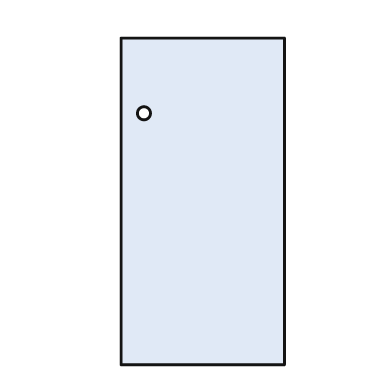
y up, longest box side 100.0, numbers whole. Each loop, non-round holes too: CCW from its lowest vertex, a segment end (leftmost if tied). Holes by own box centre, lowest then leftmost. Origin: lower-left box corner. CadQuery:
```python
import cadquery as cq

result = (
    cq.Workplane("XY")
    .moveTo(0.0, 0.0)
    .lineTo(50.0, 0.0)
    .lineTo(50.0, 100.0)
    .lineTo(0.0, 100.0)
    .close()
    .moveTo(7.0, 77.0)
    .circle(2.0)
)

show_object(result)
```